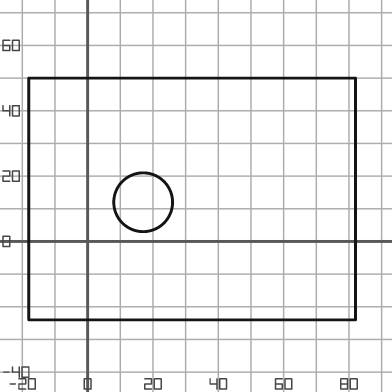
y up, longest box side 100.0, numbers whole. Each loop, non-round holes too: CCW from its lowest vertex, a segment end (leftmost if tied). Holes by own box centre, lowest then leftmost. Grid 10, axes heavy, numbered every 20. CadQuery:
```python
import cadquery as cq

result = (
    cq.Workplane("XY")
    .moveTo(-18.0, -24.0)
    .lineTo(82.0, -24.0)
    .lineTo(82.0, 50.0)
    .lineTo(-18.0, 50.0)
    .close()
    .moveTo(17.0, 12.0)
    .circle(9.0)
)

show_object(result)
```